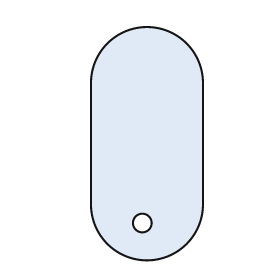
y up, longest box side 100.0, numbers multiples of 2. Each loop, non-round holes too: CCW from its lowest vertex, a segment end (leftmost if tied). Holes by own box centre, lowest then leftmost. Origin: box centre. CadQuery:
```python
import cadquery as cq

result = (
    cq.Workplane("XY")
    .moveTo(-24.0, -26.0)
    .threePointArc((0.0, -50.0), (24.0, -26.0))
    .lineTo(24.0, 26.0)
    .threePointArc((0.0, 50.0), (-24.0, 26.0))
    .close()
    .moveTo(-2.0, -34.0)
    .circle(4.0)
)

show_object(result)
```